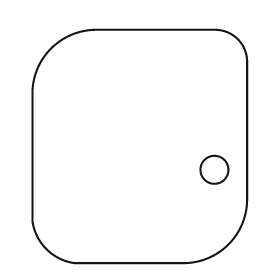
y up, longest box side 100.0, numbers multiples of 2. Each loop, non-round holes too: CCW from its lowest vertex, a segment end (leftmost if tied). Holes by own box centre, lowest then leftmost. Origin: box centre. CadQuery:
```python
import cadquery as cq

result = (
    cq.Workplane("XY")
    .moveTo(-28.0, -50.0)
    .lineTo(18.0, -50.0)
    .threePointArc((38.0, -42.0), (46.0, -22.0))
    .lineTo(46.0, 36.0)
    .threePointArc((42.0, 46.0), (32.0, 50.0))
    .lineTo(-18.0, 50.0)
    .threePointArc((-38.0, 42.0), (-46.0, 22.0))
    .lineTo(-46.0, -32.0)
    .threePointArc((-40.0, -44.0), (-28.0, -50.0))
    .close()
    .moveTo(32.0, -10.0)
    .circle(6.0)
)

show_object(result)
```